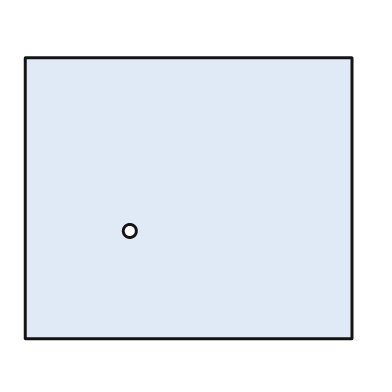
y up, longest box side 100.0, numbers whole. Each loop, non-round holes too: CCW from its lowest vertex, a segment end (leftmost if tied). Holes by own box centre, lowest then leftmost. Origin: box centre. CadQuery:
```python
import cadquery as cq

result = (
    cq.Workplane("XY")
    .moveTo(-50.0, -43.0)
    .lineTo(50.0, -43.0)
    .lineTo(50.0, 43.0)
    .lineTo(-50.0, 43.0)
    .close()
    .moveTo(-18.0, -10.0)
    .circle(2.0)
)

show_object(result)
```